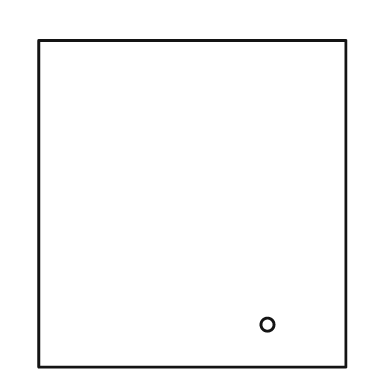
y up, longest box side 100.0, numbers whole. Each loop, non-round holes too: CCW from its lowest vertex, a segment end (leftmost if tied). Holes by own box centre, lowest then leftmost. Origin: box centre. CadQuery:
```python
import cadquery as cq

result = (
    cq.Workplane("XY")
    .moveTo(-47.0, -50.0)
    .lineTo(47.0, -50.0)
    .lineTo(47.0, 50.0)
    .lineTo(-47.0, 50.0)
    .close()
    .moveTo(23.0, -37.0)
    .circle(2.0)
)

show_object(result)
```